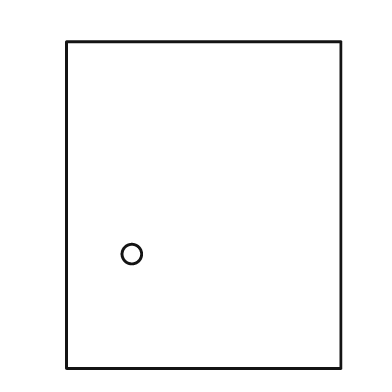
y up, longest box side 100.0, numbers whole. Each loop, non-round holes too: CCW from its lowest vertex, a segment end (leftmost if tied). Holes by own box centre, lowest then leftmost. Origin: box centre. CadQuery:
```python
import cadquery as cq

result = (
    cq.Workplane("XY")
    .moveTo(-42.0, -50.0)
    .lineTo(42.0, -50.0)
    .lineTo(42.0, 50.0)
    .lineTo(-42.0, 50.0)
    .close()
    .moveTo(-22.0, -15.0)
    .circle(3.0)
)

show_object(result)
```